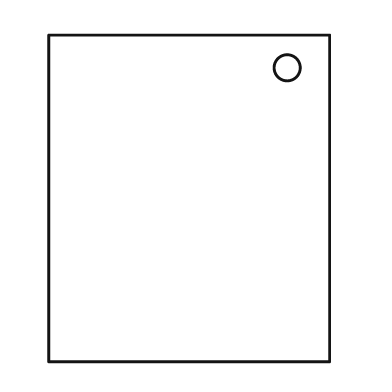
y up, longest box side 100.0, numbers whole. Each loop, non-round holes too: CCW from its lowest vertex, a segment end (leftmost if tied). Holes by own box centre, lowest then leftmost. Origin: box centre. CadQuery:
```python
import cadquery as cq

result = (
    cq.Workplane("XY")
    .moveTo(-43.0, -50.0)
    .lineTo(43.0, -50.0)
    .lineTo(43.0, 50.0)
    .lineTo(-43.0, 50.0)
    .close()
    .moveTo(30.0, 40.0)
    .circle(4.0)
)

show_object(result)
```